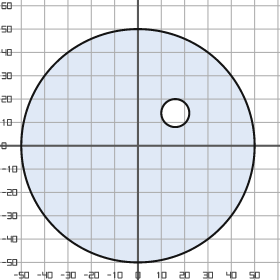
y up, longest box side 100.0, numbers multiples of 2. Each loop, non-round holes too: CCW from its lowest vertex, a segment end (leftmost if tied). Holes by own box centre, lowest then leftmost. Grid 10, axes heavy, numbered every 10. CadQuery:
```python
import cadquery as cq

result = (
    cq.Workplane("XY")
    .moveTo(0.0, 0.0)
    .circle(50.0)
    .moveTo(16.0, 14.0)
    .circle(6.0)
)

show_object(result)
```